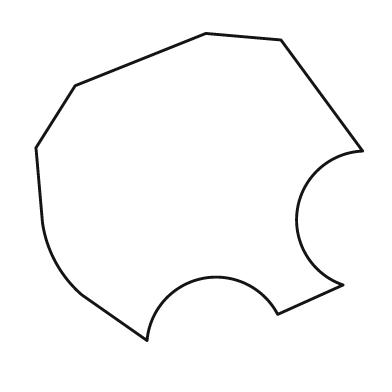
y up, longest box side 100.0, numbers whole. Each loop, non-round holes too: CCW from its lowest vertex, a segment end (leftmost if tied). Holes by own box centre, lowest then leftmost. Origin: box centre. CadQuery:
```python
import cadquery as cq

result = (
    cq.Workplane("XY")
    .moveTo(-16.0, -47.0)
    .threePointArc((1.0, -28.0), (24.0, -39.0))
    .lineTo(44.0, -30.0)
    .threePointArc((30.0, -7.0), (50.0, 11.0))
    .lineTo(25.0, 45.0)
    .lineTo(2.0, 47.0)
    .lineTo(-38.0, 31.0)
    .lineTo(-50.0, 12.0)
    .lineTo(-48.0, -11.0)
    .threePointArc((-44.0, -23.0), (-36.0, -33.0))
    .close()
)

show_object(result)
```